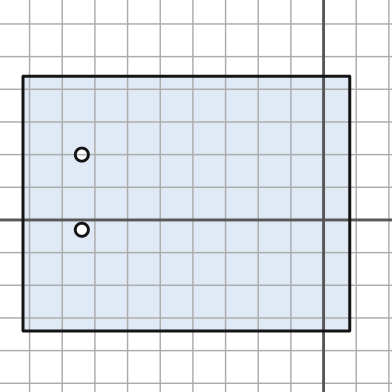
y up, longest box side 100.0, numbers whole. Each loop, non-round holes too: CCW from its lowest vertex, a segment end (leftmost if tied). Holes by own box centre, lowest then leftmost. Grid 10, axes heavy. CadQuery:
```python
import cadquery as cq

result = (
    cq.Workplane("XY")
    .moveTo(-92.0, -34.0)
    .lineTo(8.0, -34.0)
    .lineTo(8.0, 44.0)
    .lineTo(-92.0, 44.0)
    .close()
    .moveTo(-74.0, -3.0)
    .circle(2.0)
    .moveTo(-74.0, 20.0)
    .circle(2.0)
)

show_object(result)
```